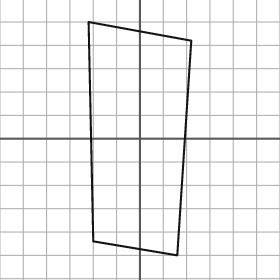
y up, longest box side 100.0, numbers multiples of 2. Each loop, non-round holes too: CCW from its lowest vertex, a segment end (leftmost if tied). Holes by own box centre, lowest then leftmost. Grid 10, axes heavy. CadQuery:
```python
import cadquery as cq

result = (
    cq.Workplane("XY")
    .moveTo(16.0, -50.0)
    .lineTo(22.0, 42.0)
    .lineTo(-22.0, 50.0)
    .lineTo(-20.0, -44.0)
    .close()
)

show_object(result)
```